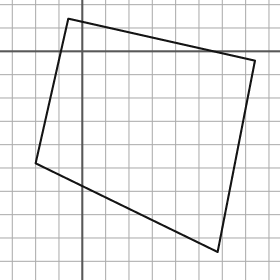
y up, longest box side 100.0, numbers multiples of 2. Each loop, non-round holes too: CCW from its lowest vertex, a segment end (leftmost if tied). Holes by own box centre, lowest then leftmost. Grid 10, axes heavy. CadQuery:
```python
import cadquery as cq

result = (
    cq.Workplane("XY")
    .moveTo(58.0, -86.0)
    .lineTo(74.0, -4.0)
    .lineTo(-6.0, 14.0)
    .lineTo(-20.0, -48.0)
    .close()
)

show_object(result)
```